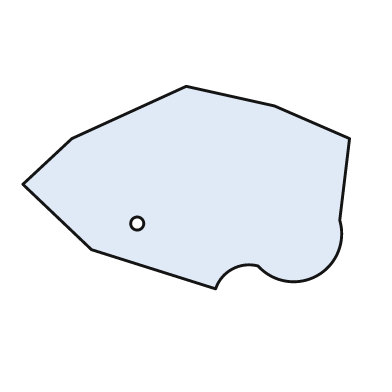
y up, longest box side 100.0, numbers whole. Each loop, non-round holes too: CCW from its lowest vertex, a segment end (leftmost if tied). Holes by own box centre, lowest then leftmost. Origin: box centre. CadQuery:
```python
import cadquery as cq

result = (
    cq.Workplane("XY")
    .moveTo(9.0, -31.0)
    .threePointArc((14.0, -25.0), (22.0, -24.0))
    .threePointArc((40.0, -27.0), (47.0, -10.0))
    .lineTo(50.0, 15.0)
    .lineTo(27.0, 25.0)
    .lineTo(0.0, 31.0)
    .lineTo(-35.0, 15.0)
    .lineTo(-50.0, 1.0)
    .lineTo(-29.0, -19.0)
    .close()
    .moveTo(-15.0, -11.0)
    .circle(2.0)
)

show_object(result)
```